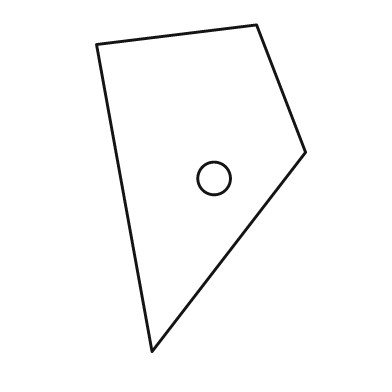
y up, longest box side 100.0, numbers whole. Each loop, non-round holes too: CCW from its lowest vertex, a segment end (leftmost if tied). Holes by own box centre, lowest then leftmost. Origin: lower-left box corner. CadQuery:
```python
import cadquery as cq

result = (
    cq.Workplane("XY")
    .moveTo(17.0, 0.0)
    .lineTo(64.0, 61.0)
    .lineTo(49.0, 100.0)
    .lineTo(0.0, 94.0)
    .close()
    .moveTo(36.0, 53.0)
    .circle(5.0)
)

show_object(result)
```